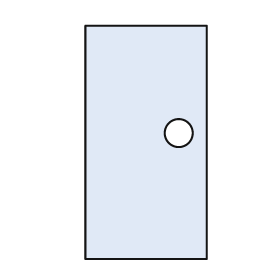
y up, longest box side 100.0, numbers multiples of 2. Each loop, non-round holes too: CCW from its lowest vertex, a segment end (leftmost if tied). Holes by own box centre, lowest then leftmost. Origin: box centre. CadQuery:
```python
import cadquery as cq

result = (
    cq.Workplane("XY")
    .moveTo(-26.0, -50.0)
    .lineTo(26.0, -50.0)
    .lineTo(26.0, 50.0)
    .lineTo(-26.0, 50.0)
    .close()
    .moveTo(14.0, 4.0)
    .circle(6.0)
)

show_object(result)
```